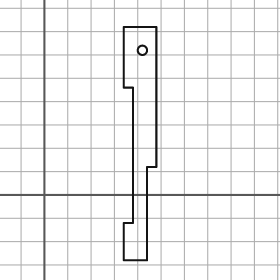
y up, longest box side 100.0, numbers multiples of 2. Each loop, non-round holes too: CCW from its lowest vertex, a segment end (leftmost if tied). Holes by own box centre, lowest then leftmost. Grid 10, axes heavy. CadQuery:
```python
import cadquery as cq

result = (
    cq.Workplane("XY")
    .moveTo(34.0, -28.0)
    .lineTo(44.0, -28.0)
    .lineTo(44.0, 12.0)
    .lineTo(48.0, 12.0)
    .lineTo(48.0, 72.0)
    .lineTo(34.0, 72.0)
    .lineTo(34.0, 46.0)
    .lineTo(38.0, 46.0)
    .lineTo(38.0, -12.0)
    .lineTo(34.0, -12.0)
    .close()
    .moveTo(42.0, 62.0)
    .circle(2.0)
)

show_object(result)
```